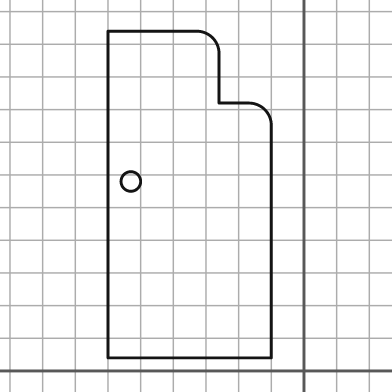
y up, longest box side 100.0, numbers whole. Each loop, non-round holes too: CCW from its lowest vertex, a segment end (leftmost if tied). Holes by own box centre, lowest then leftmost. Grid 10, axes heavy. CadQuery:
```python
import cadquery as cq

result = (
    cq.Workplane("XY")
    .moveTo(-60.0, 4.0)
    .lineTo(-10.0, 4.0)
    .lineTo(-10.0, 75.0)
    .threePointArc((-12.0, 80.0), (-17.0, 82.0))
    .lineTo(-26.0, 82.0)
    .lineTo(-26.0, 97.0)
    .threePointArc((-28.0, 102.0), (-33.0, 104.0))
    .lineTo(-60.0, 104.0)
    .close()
    .moveTo(-53.0, 58.0)
    .circle(3.0)
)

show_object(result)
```